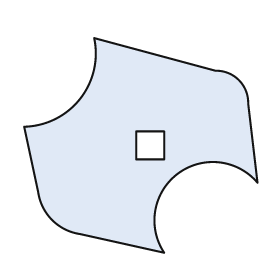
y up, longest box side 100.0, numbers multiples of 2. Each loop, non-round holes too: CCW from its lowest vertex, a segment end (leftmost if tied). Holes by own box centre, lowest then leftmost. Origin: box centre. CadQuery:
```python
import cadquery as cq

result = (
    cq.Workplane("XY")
    .moveTo(10.0, -46.0)
    .threePointArc((16.0, -12.0), (50.0, -16.0))
    .lineTo(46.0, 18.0)
    .threePointArc((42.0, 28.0), (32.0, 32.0))
    .lineTo(-20.0, 46.0)
    .threePointArc((-26.0, 20.0), (-50.0, 8.0))
    .lineTo(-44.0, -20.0)
    .threePointArc((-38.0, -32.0), (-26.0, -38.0))
    .close()
    .moveTo(-2.0, -6.0)
    .lineTo(10.0, -6.0)
    .lineTo(10.0, 6.0)
    .lineTo(-2.0, 6.0)
    .close()
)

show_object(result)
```